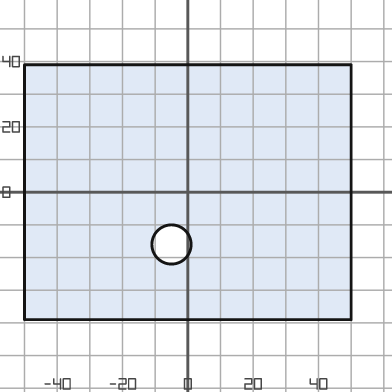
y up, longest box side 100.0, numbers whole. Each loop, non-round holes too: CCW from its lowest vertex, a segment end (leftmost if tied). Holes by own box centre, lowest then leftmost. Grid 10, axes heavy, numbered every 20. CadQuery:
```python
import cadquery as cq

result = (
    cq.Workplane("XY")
    .moveTo(-50.0, -39.0)
    .lineTo(50.0, -39.0)
    .lineTo(50.0, 39.0)
    .lineTo(-50.0, 39.0)
    .close()
    .moveTo(-5.0, -16.0)
    .circle(6.0)
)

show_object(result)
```